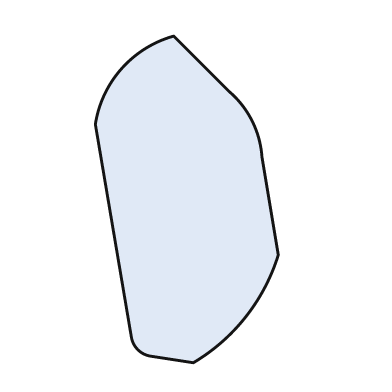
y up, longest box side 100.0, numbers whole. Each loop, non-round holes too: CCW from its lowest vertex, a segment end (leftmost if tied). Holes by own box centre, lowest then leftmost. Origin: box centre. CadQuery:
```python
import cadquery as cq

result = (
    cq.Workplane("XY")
    .moveTo(2.0, -50.0)
    .threePointArc((18.0, -36.0), (28.0, -17.0))
    .lineTo(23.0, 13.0)
    .threePointArc((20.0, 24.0), (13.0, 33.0))
    .lineTo(-4.0, 50.0)
    .threePointArc((-20.0, 40.0), (-28.0, 23.0))
    .lineTo(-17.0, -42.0)
    .threePointArc((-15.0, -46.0), (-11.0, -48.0))
    .close()
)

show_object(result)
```